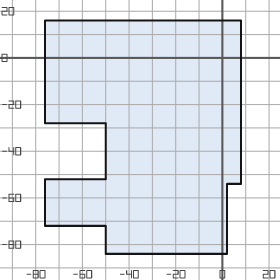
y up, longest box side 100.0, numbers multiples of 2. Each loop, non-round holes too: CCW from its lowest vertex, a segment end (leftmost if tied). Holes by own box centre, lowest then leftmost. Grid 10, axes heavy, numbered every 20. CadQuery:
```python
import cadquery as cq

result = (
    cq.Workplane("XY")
    .moveTo(-50.0, -84.0)
    .lineTo(2.0, -84.0)
    .lineTo(2.0, -54.0)
    .lineTo(8.0, -54.0)
    .lineTo(8.0, 16.0)
    .lineTo(-76.0, 16.0)
    .lineTo(-76.0, -28.0)
    .lineTo(-50.0, -28.0)
    .lineTo(-50.0, -52.0)
    .lineTo(-76.0, -52.0)
    .lineTo(-76.0, -72.0)
    .lineTo(-50.0, -72.0)
    .close()
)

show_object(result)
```